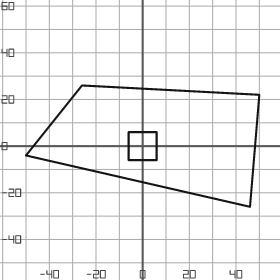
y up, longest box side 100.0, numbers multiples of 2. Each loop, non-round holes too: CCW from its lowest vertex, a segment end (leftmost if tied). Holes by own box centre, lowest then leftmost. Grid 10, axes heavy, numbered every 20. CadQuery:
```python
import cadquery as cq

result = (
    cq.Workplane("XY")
    .moveTo(46.0, -26.0)
    .lineTo(50.0, 22.0)
    .lineTo(-26.0, 26.0)
    .lineTo(-50.0, -4.0)
    .close()
    .moveTo(-6.0, -6.0)
    .lineTo(6.0, -6.0)
    .lineTo(6.0, 6.0)
    .lineTo(-6.0, 6.0)
    .close()
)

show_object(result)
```